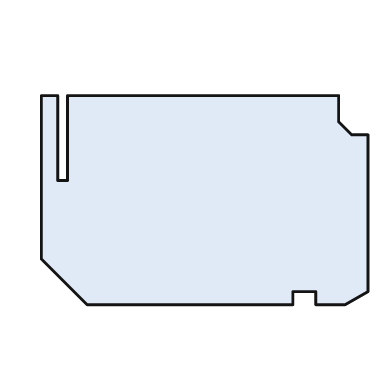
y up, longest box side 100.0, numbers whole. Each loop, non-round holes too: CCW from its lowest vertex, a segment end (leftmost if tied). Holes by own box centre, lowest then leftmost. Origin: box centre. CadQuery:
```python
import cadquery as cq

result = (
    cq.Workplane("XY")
    .moveTo(-36.0, -32.0)
    .lineTo(27.0, -32.0)
    .lineTo(27.0, -28.0)
    .lineTo(34.0, -28.0)
    .lineTo(34.0, -32.0)
    .lineTo(43.0, -32.0)
    .lineTo(50.0, -28.0)
    .lineTo(50.0, 20.0)
    .lineTo(45.0, 20.0)
    .lineTo(41.0, 24.0)
    .lineTo(41.0, 32.0)
    .lineTo(-42.0, 32.0)
    .lineTo(-42.0, 6.0)
    .lineTo(-45.0, 6.0)
    .lineTo(-45.0, 32.0)
    .lineTo(-50.0, 32.0)
    .lineTo(-50.0, -18.0)
    .close()
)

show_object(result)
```